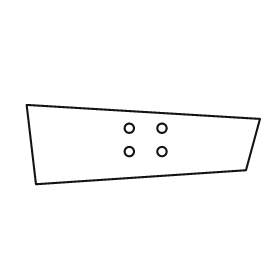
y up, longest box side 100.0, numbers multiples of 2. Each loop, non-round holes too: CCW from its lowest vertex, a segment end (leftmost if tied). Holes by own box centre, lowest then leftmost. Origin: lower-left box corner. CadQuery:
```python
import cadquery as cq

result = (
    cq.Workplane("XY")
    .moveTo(4.0, 0.0)
    .lineTo(94.0, 6.0)
    .lineTo(100.0, 28.0)
    .lineTo(0.0, 34.0)
    .close()
    .moveTo(44.0, 14.0)
    .circle(2.0)
    .moveTo(58.0, 14.0)
    .circle(2.0)
    .moveTo(44.0, 24.0)
    .circle(2.0)
    .moveTo(58.0, 24.0)
    .circle(2.0)
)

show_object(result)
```